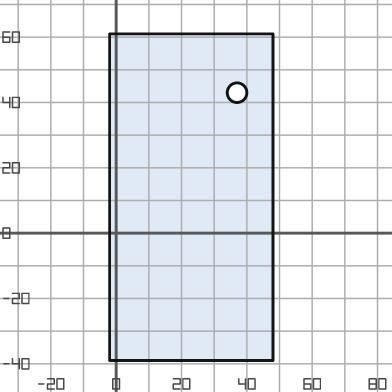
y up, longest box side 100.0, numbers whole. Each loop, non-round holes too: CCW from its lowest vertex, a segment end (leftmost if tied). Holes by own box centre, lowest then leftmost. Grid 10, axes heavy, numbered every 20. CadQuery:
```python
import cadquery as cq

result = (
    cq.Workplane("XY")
    .moveTo(-2.0, -39.0)
    .lineTo(48.0, -39.0)
    .lineTo(48.0, 61.0)
    .lineTo(-2.0, 61.0)
    .close()
    .moveTo(37.0, 43.0)
    .circle(3.0)
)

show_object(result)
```